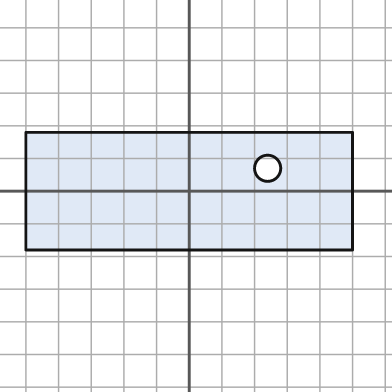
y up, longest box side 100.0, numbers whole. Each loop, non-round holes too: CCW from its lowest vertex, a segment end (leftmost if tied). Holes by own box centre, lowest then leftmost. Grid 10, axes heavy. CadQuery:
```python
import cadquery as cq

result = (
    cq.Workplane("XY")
    .moveTo(-50.0, -18.0)
    .lineTo(50.0, -18.0)
    .lineTo(50.0, 18.0)
    .lineTo(-50.0, 18.0)
    .close()
    .moveTo(24.0, 7.0)
    .circle(4.0)
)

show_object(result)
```